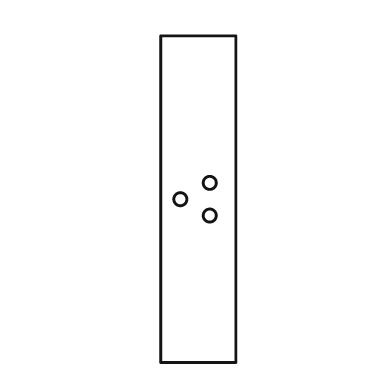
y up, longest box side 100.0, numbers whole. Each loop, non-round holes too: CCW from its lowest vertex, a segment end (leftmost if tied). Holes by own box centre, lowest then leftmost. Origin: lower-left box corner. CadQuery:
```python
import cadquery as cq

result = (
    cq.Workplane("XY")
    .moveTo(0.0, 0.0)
    .lineTo(23.0, 0.0)
    .lineTo(23.0, 100.0)
    .lineTo(0.0, 100.0)
    .close()
    .moveTo(15.0, 45.0)
    .circle(2.0)
    .moveTo(6.0, 50.0)
    .circle(2.0)
    .moveTo(15.0, 55.0)
    .circle(2.0)
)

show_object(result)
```